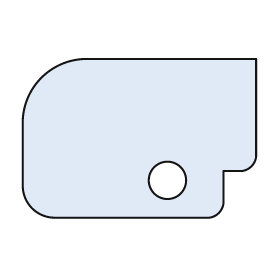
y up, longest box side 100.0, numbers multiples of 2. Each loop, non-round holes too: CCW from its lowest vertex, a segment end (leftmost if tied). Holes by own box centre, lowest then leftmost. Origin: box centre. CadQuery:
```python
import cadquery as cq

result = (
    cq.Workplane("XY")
    .moveTo(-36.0, -34.0)
    .lineTo(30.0, -34.0)
    .threePointArc((34.0, -32.0), (36.0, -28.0))
    .lineTo(36.0, -14.0)
    .lineTo(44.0, -14.0)
    .threePointArc((48.0, -12.0), (50.0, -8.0))
    .lineTo(50.0, 34.0)
    .lineTo(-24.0, 34.0)
    .threePointArc((-42.0, 26.0), (-50.0, 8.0))
    .lineTo(-50.0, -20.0)
    .threePointArc((-46.0, -30.0), (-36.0, -34.0))
    .close()
    .moveTo(12.0, -18.0)
    .circle(8.0)
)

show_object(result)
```